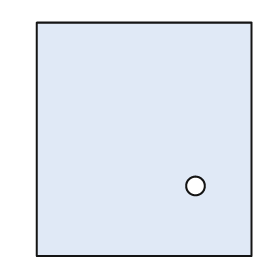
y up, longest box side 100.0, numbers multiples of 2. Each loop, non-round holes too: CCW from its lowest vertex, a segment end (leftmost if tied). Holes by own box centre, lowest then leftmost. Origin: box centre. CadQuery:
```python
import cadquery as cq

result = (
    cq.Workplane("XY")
    .moveTo(-46.0, -50.0)
    .lineTo(46.0, -50.0)
    .lineTo(46.0, 50.0)
    .lineTo(-46.0, 50.0)
    .close()
    .moveTo(22.0, -20.0)
    .circle(4.0)
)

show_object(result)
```